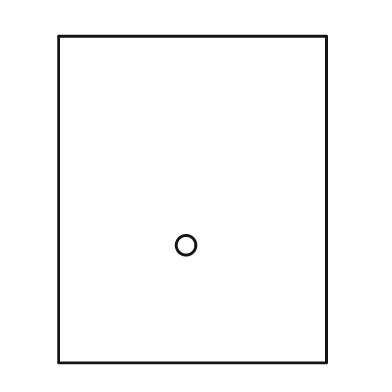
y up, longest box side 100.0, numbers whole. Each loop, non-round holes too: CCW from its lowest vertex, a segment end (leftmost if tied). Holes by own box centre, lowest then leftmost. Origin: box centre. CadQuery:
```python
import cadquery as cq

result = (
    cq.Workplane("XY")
    .moveTo(-41.0, -50.0)
    .lineTo(41.0, -50.0)
    .lineTo(41.0, 50.0)
    .lineTo(-41.0, 50.0)
    .close()
    .moveTo(-2.0, -14.0)
    .circle(3.0)
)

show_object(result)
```